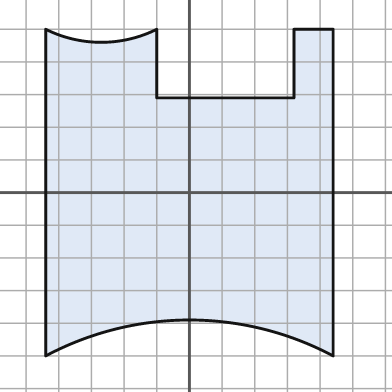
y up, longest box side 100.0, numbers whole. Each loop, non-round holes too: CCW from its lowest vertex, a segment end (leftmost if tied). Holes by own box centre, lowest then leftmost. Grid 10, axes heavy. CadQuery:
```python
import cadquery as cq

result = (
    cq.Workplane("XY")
    .moveTo(-44.0, -50.0)
    .threePointArc((0.0, -39.0), (44.0, -50.0))
    .lineTo(44.0, 50.0)
    .lineTo(32.0, 50.0)
    .lineTo(32.0, 29.0)
    .lineTo(-10.0, 29.0)
    .lineTo(-10.0, 50.0)
    .threePointArc((-27.0, 46.0), (-44.0, 50.0))
    .close()
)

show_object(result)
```